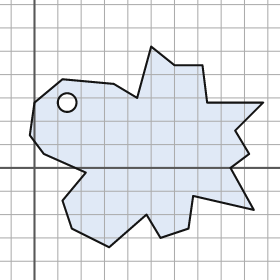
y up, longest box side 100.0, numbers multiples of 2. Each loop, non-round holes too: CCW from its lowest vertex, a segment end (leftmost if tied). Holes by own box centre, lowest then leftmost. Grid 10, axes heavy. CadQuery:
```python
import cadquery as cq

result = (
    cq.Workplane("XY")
    .moveTo(32.0, -34.0)
    .lineTo(48.0, -20.0)
    .lineTo(54.0, -30.0)
    .lineTo(66.0, -26.0)
    .lineTo(68.0, -12.0)
    .lineTo(94.0, -18.0)
    .lineTo(84.0, 0.0)
    .lineTo(92.0, 6.0)
    .lineTo(86.0, 16.0)
    .lineTo(98.0, 28.0)
    .lineTo(74.0, 28.0)
    .lineTo(72.0, 44.0)
    .lineTo(60.0, 44.0)
    .lineTo(50.0, 52.0)
    .lineTo(44.0, 30.0)
    .lineTo(34.0, 36.0)
    .lineTo(12.0, 38.0)
    .lineTo(0.0, 28.0)
    .lineTo(-2.0, 14.0)
    .lineTo(4.0, 6.0)
    .lineTo(22.0, -2.0)
    .lineTo(12.0, -14.0)
    .lineTo(16.0, -26.0)
    .close()
    .moveTo(14.0, 28.0)
    .circle(4.0)
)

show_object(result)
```